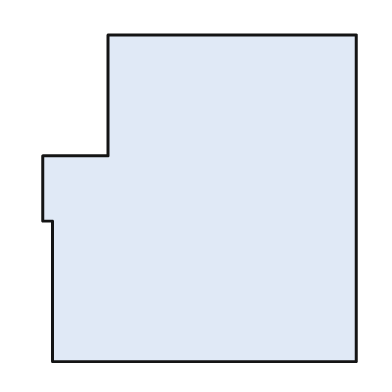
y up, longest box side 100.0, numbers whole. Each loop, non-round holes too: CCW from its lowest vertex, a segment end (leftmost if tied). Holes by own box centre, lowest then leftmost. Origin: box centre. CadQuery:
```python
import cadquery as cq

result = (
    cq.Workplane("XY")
    .moveTo(-45.0, -50.0)
    .lineTo(48.0, -50.0)
    .lineTo(48.0, 50.0)
    .lineTo(-28.0, 50.0)
    .lineTo(-28.0, 13.0)
    .lineTo(-48.0, 13.0)
    .lineTo(-48.0, -7.0)
    .lineTo(-45.0, -7.0)
    .close()
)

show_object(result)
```